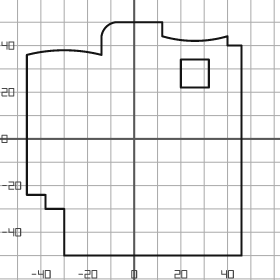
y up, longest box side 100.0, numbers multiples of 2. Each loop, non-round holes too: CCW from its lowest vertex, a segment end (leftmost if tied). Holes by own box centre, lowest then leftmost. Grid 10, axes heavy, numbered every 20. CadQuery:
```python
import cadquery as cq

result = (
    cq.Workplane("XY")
    .moveTo(-30.0, -50.0)
    .lineTo(46.0, -50.0)
    .lineTo(46.0, 40.0)
    .lineTo(40.0, 40.0)
    .lineTo(40.0, 44.0)
    .threePointArc((26.0, 42.0), (12.0, 44.0))
    .lineTo(12.0, 50.0)
    .lineTo(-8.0, 50.0)
    .threePointArc((-12.0, 48.0), (-14.0, 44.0))
    .lineTo(-14.0, 36.0)
    .threePointArc((-30.0, 38.0), (-46.0, 36.0))
    .lineTo(-46.0, -24.0)
    .lineTo(-38.0, -24.0)
    .lineTo(-38.0, -30.0)
    .lineTo(-30.0, -30.0)
    .close()
    .moveTo(20.0, 22.0)
    .lineTo(32.0, 22.0)
    .lineTo(32.0, 34.0)
    .lineTo(20.0, 34.0)
    .close()
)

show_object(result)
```